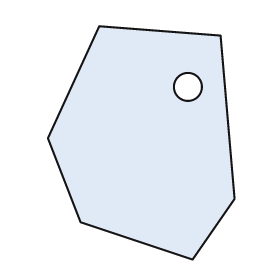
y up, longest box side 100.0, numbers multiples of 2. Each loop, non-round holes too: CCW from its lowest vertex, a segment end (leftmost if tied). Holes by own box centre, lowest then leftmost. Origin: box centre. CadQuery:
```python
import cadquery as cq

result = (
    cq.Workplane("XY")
    .moveTo(22.0, -50.0)
    .lineTo(40.0, -24.0)
    .lineTo(34.0, 46.0)
    .lineTo(-18.0, 50.0)
    .lineTo(-40.0, 2.0)
    .lineTo(-26.0, -34.0)
    .close()
    .moveTo(20.0, 24.0)
    .circle(6.0)
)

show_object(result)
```